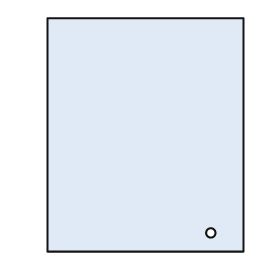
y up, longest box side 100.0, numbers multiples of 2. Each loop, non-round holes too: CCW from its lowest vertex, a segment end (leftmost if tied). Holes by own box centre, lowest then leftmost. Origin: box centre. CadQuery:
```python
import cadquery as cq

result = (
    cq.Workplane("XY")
    .moveTo(-42.0, -50.0)
    .lineTo(42.0, -50.0)
    .lineTo(42.0, 50.0)
    .lineTo(-42.0, 50.0)
    .close()
    .moveTo(28.0, -42.0)
    .circle(2.0)
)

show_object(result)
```